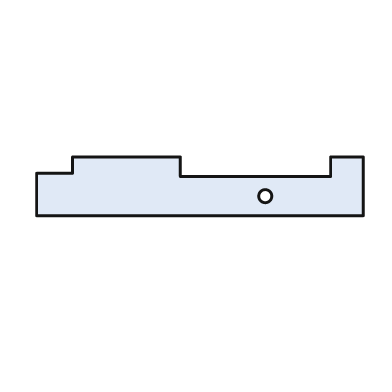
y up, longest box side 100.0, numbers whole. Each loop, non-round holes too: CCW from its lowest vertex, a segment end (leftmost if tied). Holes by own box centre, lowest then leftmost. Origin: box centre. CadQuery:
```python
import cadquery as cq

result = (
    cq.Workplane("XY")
    .moveTo(-50.0, -9.0)
    .lineTo(50.0, -9.0)
    .lineTo(50.0, 9.0)
    .lineTo(40.0, 9.0)
    .lineTo(40.0, 3.0)
    .lineTo(-6.0, 3.0)
    .lineTo(-6.0, 9.0)
    .lineTo(-39.0, 9.0)
    .lineTo(-39.0, 4.0)
    .lineTo(-50.0, 4.0)
    .close()
    .moveTo(20.0, -3.0)
    .circle(2.0)
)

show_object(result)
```